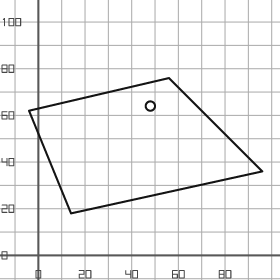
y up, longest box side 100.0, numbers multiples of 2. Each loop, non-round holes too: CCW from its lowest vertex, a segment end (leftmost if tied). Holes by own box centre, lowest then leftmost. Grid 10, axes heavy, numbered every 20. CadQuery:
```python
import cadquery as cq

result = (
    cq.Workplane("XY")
    .moveTo(14.0, 18.0)
    .lineTo(96.0, 36.0)
    .lineTo(56.0, 76.0)
    .lineTo(-4.0, 62.0)
    .close()
    .moveTo(48.0, 64.0)
    .circle(2.0)
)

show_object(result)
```